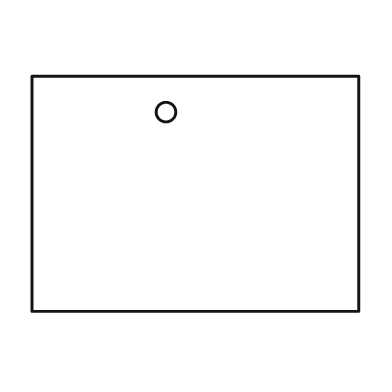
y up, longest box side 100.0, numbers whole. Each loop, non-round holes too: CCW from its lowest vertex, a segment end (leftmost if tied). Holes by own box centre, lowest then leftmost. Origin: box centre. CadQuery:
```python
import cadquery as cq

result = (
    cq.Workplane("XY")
    .moveTo(-50.0, -36.0)
    .lineTo(50.0, -36.0)
    .lineTo(50.0, 36.0)
    .lineTo(-50.0, 36.0)
    .close()
    .moveTo(-9.0, 25.0)
    .circle(3.0)
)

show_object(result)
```